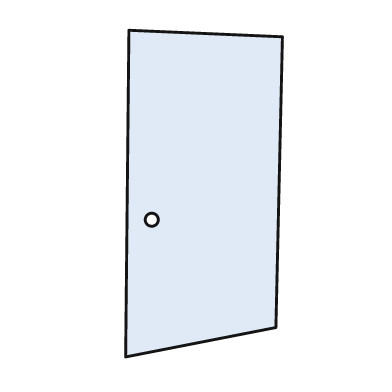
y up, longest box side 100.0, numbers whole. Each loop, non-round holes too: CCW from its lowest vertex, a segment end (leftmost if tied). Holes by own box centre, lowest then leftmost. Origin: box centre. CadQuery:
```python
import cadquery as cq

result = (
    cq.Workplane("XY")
    .moveTo(-24.0, -50.0)
    .lineTo(22.0, -41.0)
    .lineTo(24.0, 48.0)
    .lineTo(-23.0, 50.0)
    .close()
    .moveTo(-16.0, -8.0)
    .circle(2.0)
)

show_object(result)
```